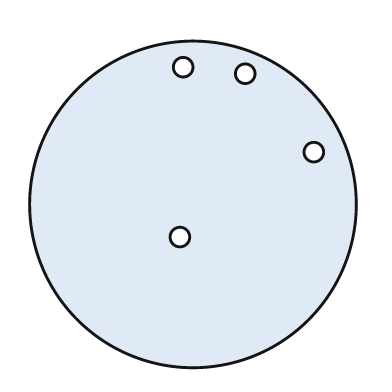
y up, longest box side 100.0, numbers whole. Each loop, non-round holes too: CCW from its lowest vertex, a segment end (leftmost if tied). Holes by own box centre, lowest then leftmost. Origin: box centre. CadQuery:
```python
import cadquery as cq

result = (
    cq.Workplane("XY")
    .moveTo(0.0, 0.0)
    .circle(50.0)
    .moveTo(-4.0, -10.0)
    .circle(3.0)
    .moveTo(37.0, 16.0)
    .circle(3.0)
    .moveTo(16.0, 40.0)
    .circle(3.0)
    .moveTo(-3.0, 42.0)
    .circle(3.0)
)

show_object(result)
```